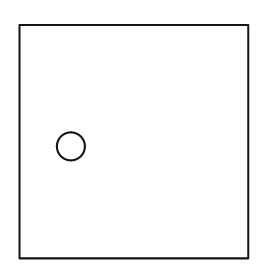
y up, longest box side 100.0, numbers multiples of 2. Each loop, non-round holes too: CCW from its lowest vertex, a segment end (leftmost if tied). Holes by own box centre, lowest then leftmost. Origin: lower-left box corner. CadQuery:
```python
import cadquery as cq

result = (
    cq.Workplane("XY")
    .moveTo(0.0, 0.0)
    .lineTo(98.0, 0.0)
    .lineTo(98.0, 100.0)
    .lineTo(0.0, 100.0)
    .close()
    .moveTo(22.0, 48.0)
    .circle(6.0)
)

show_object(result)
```